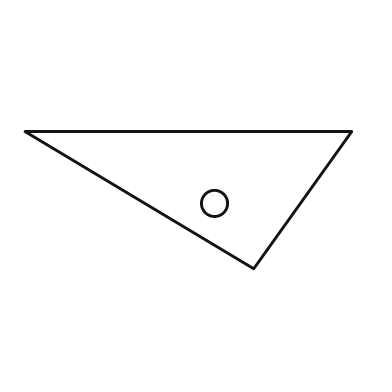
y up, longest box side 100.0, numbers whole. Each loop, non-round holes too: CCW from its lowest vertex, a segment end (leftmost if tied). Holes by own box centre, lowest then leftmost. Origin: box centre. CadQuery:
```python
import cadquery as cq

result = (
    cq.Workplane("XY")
    .moveTo(20.0, -21.0)
    .lineTo(50.0, 21.0)
    .lineTo(-50.0, 21.0)
    .close()
    .moveTo(8.0, -1.0)
    .circle(4.0)
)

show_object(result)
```